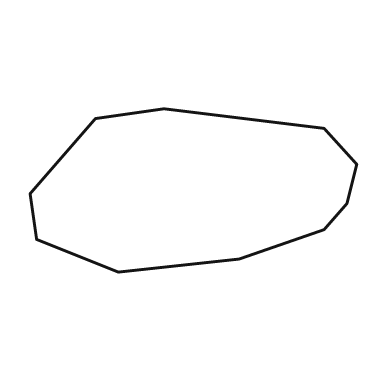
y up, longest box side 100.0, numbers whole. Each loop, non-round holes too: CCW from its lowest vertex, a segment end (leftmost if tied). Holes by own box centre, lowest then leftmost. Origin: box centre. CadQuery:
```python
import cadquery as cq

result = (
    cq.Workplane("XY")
    .moveTo(-23.0, -25.0)
    .lineTo(14.0, -21.0)
    .lineTo(40.0, -12.0)
    .lineTo(47.0, -4.0)
    .lineTo(50.0, 8.0)
    .lineTo(40.0, 19.0)
    .lineTo(-9.0, 25.0)
    .lineTo(-30.0, 22.0)
    .lineTo(-50.0, -1.0)
    .lineTo(-48.0, -15.0)
    .close()
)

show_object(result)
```